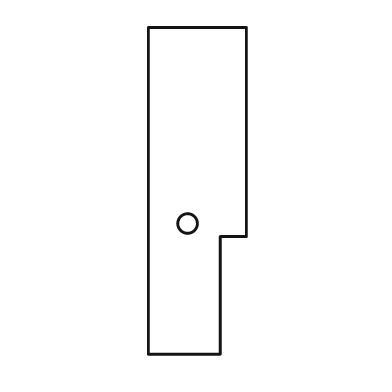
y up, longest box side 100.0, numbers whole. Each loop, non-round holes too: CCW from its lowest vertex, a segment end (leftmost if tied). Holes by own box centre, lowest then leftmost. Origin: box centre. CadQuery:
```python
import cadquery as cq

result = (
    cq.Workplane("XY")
    .moveTo(-15.0, -50.0)
    .lineTo(7.0, -50.0)
    .lineTo(7.0, -14.0)
    .lineTo(15.0, -14.0)
    .lineTo(15.0, 50.0)
    .lineTo(-15.0, 50.0)
    .close()
    .moveTo(-3.0, -10.0)
    .circle(3.0)
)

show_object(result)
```